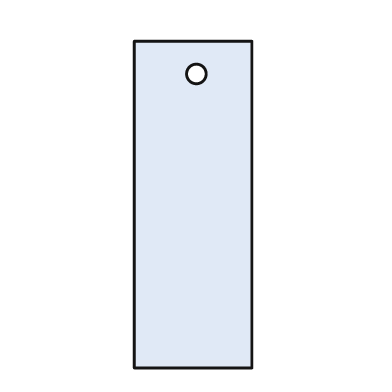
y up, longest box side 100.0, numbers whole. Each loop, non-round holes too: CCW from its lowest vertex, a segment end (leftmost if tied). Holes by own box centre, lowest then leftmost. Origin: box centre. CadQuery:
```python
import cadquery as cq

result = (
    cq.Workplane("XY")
    .moveTo(-18.0, -50.0)
    .lineTo(18.0, -50.0)
    .lineTo(18.0, 50.0)
    .lineTo(-18.0, 50.0)
    .close()
    .moveTo(1.0, 40.0)
    .circle(3.0)
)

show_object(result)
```